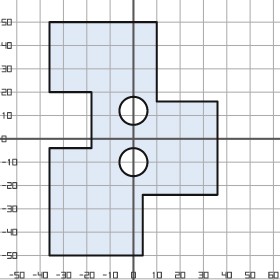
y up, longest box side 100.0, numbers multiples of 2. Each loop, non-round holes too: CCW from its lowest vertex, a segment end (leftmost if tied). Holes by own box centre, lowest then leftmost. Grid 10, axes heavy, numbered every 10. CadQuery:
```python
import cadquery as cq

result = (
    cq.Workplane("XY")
    .moveTo(-36.0, -50.0)
    .lineTo(4.0, -50.0)
    .lineTo(4.0, -24.0)
    .lineTo(36.0, -24.0)
    .lineTo(36.0, 16.0)
    .lineTo(10.0, 16.0)
    .lineTo(10.0, 50.0)
    .lineTo(-36.0, 50.0)
    .lineTo(-36.0, 20.0)
    .lineTo(-18.0, 20.0)
    .lineTo(-18.0, -4.0)
    .lineTo(-36.0, -4.0)
    .close()
    .moveTo(0.0, -10.0)
    .circle(6.0)
    .moveTo(0.0, 12.0)
    .circle(6.0)
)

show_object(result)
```